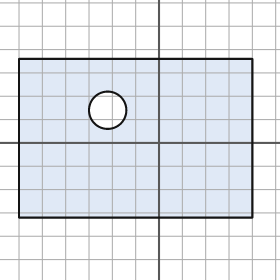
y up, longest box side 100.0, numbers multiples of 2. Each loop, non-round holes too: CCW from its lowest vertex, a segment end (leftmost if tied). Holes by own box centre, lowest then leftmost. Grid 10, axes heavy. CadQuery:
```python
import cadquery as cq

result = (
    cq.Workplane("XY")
    .moveTo(-60.0, -32.0)
    .lineTo(40.0, -32.0)
    .lineTo(40.0, 36.0)
    .lineTo(-60.0, 36.0)
    .close()
    .moveTo(-22.0, 14.0)
    .circle(8.0)
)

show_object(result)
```